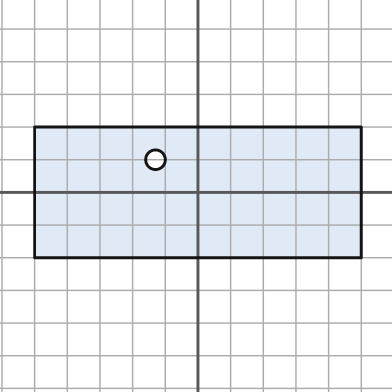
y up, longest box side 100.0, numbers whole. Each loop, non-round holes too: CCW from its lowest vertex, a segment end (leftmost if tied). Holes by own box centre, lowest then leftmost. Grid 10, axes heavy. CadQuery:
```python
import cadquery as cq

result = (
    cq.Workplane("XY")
    .moveTo(-50.0, -20.0)
    .lineTo(50.0, -20.0)
    .lineTo(50.0, 20.0)
    .lineTo(-50.0, 20.0)
    .close()
    .moveTo(-13.0, 10.0)
    .circle(3.0)
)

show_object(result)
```